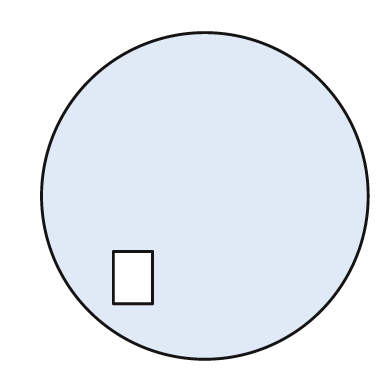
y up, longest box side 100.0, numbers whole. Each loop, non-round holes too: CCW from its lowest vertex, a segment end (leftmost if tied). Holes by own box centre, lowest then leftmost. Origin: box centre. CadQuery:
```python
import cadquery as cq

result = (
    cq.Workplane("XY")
    .moveTo(0.0, 0.0)
    .circle(50.0)
    .moveTo(-28.0, -33.0)
    .lineTo(-16.0, -33.0)
    .lineTo(-16.0, -17.0)
    .lineTo(-28.0, -17.0)
    .close()
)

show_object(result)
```